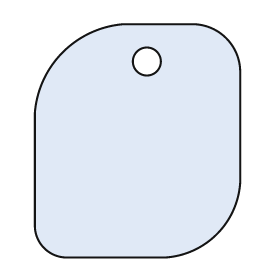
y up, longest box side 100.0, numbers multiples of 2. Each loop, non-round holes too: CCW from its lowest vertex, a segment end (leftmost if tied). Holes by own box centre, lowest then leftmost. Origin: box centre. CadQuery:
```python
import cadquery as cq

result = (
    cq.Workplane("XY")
    .moveTo(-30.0, -50.0)
    .lineTo(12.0, -50.0)
    .threePointArc((34.0, -40.0), (44.0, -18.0))
    .lineTo(44.0, 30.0)
    .threePointArc((38.0, 44.0), (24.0, 50.0))
    .lineTo(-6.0, 50.0)
    .threePointArc((-32.0, 38.0), (-44.0, 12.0))
    .lineTo(-44.0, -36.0)
    .threePointArc((-40.0, -46.0), (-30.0, -50.0))
    .close()
    .moveTo(4.0, 34.0)
    .circle(6.0)
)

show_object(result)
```